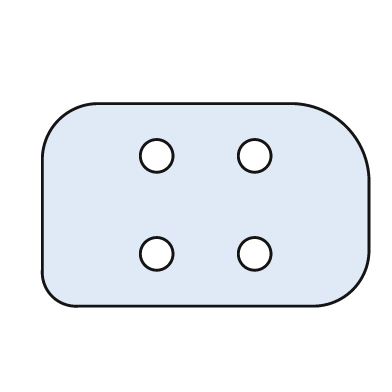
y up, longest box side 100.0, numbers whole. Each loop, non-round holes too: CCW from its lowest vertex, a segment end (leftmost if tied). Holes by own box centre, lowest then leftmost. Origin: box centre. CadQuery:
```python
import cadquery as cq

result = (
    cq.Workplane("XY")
    .moveTo(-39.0, -31.0)
    .lineTo(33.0, -31.0)
    .threePointArc((45.0, -26.0), (50.0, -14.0))
    .lineTo(50.0, 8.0)
    .threePointArc((43.0, 24.0), (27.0, 31.0))
    .lineTo(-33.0, 31.0)
    .threePointArc((-45.0, 26.0), (-50.0, 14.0))
    .lineTo(-50.0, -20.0)
    .threePointArc((-47.0, -28.0), (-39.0, -31.0))
    .close()
    .moveTo(-15.0, -15.0)
    .circle(5.0)
    .moveTo(15.0, -15.0)
    .circle(5.0)
    .moveTo(-15.0, 15.0)
    .circle(5.0)
    .moveTo(15.0, 15.0)
    .circle(5.0)
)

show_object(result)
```